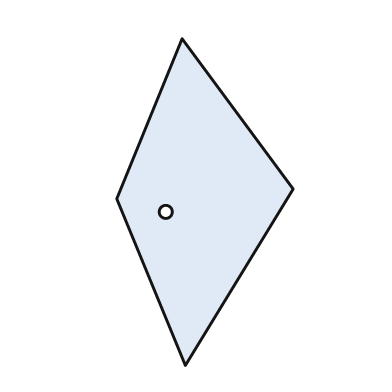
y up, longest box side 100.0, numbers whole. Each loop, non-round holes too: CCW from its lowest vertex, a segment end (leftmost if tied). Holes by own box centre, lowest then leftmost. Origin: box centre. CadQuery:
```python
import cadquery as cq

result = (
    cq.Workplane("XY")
    .moveTo(-6.0, -50.0)
    .lineTo(27.0, 4.0)
    .lineTo(-7.0, 50.0)
    .lineTo(-27.0, 1.0)
    .close()
    .moveTo(-12.0, -3.0)
    .circle(2.0)
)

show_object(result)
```